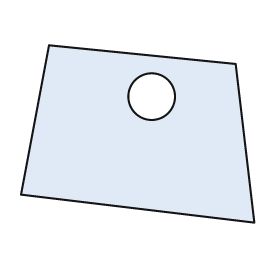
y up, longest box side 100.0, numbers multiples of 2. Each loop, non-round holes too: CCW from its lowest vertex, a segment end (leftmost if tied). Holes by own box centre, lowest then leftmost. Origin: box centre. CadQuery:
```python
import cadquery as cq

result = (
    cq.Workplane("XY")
    .moveTo(50.0, -38.0)
    .lineTo(42.0, 30.0)
    .lineTo(-38.0, 38.0)
    .lineTo(-50.0, -26.0)
    .close()
    .moveTo(6.0, 16.0)
    .circle(10.0)
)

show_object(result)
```